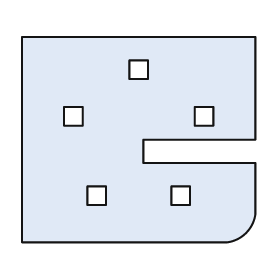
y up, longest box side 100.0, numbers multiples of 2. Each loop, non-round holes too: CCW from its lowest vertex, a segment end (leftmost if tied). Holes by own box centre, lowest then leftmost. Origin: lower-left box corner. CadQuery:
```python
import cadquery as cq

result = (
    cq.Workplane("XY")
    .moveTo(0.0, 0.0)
    .lineTo(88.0, 0.0)
    .threePointArc((96.0, 4.0), (100.0, 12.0))
    .lineTo(100.0, 34.0)
    .lineTo(52.0, 34.0)
    .lineTo(52.0, 44.0)
    .lineTo(100.0, 44.0)
    .lineTo(100.0, 88.0)
    .lineTo(0.0, 88.0)
    .close()
    .moveTo(28.0, 16.0)
    .lineTo(36.0, 16.0)
    .lineTo(36.0, 24.0)
    .lineTo(28.0, 24.0)
    .close()
    .moveTo(64.0, 16.0)
    .lineTo(72.0, 16.0)
    .lineTo(72.0, 24.0)
    .lineTo(64.0, 24.0)
    .close()
    .moveTo(18.0, 50.0)
    .lineTo(26.0, 50.0)
    .lineTo(26.0, 58.0)
    .lineTo(18.0, 58.0)
    .close()
    .moveTo(74.0, 50.0)
    .lineTo(82.0, 50.0)
    .lineTo(82.0, 58.0)
    .lineTo(74.0, 58.0)
    .close()
    .moveTo(46.0, 70.0)
    .lineTo(54.0, 70.0)
    .lineTo(54.0, 78.0)
    .lineTo(46.0, 78.0)
    .close()
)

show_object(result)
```